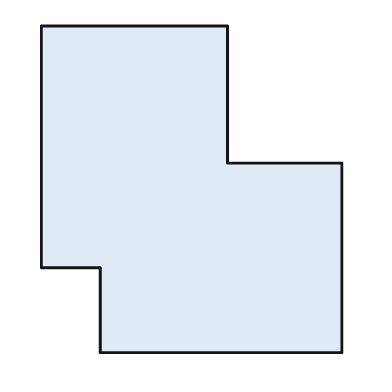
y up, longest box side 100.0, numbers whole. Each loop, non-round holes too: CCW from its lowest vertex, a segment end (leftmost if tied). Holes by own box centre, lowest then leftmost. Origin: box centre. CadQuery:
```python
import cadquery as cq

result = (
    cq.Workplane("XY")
    .moveTo(-28.0, -50.0)
    .lineTo(46.0, -50.0)
    .lineTo(46.0, 8.0)
    .lineTo(11.0, 8.0)
    .lineTo(11.0, 50.0)
    .lineTo(-46.0, 50.0)
    .lineTo(-46.0, -24.0)
    .lineTo(-28.0, -24.0)
    .close()
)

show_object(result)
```